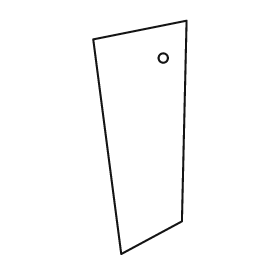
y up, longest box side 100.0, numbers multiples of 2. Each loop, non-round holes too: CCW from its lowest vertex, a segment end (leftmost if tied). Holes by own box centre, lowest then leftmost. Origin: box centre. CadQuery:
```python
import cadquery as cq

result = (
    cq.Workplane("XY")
    .moveTo(-8.0, -50.0)
    .lineTo(18.0, -36.0)
    .lineTo(20.0, 50.0)
    .lineTo(-20.0, 42.0)
    .close()
    .moveTo(10.0, 34.0)
    .circle(2.0)
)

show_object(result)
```